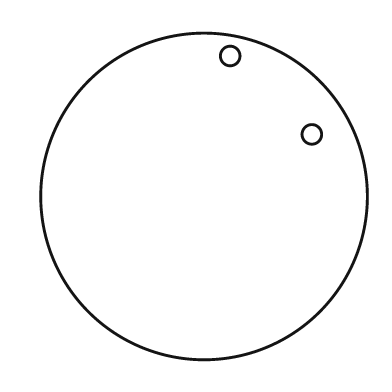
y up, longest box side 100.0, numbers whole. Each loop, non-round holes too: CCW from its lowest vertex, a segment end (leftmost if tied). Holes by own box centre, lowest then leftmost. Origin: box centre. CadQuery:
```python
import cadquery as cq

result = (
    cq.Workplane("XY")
    .moveTo(0.0, 0.0)
    .circle(50.0)
    .moveTo(33.0, 19.0)
    .circle(3.0)
    .moveTo(8.0, 43.0)
    .circle(3.0)
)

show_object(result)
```